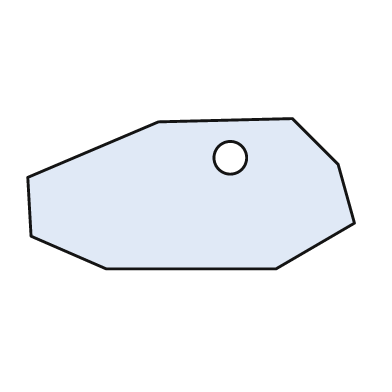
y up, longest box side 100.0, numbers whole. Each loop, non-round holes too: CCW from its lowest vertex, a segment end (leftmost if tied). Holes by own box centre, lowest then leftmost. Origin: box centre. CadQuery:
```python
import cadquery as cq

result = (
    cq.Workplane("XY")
    .moveTo(-26.0, -23.0)
    .lineTo(26.0, -23.0)
    .lineTo(50.0, -9.0)
    .lineTo(45.0, 9.0)
    .lineTo(31.0, 23.0)
    .lineTo(-10.0, 22.0)
    .lineTo(-50.0, 5.0)
    .lineTo(-49.0, -13.0)
    .close()
    .moveTo(12.0, 11.0)
    .circle(5.0)
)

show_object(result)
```